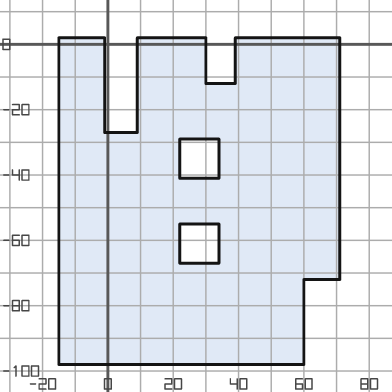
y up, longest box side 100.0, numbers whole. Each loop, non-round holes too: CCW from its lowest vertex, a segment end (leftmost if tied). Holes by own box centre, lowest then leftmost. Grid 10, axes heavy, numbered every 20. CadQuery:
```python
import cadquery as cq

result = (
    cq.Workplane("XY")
    .moveTo(-15.0, -98.0)
    .lineTo(60.0, -98.0)
    .lineTo(60.0, -72.0)
    .lineTo(71.0, -72.0)
    .lineTo(71.0, 2.0)
    .lineTo(39.0, 2.0)
    .lineTo(39.0, -12.0)
    .lineTo(30.0, -12.0)
    .lineTo(30.0, 2.0)
    .lineTo(9.0, 2.0)
    .lineTo(9.0, -27.0)
    .lineTo(-1.0, -27.0)
    .lineTo(-1.0, 2.0)
    .lineTo(-15.0, 2.0)
    .close()
    .moveTo(22.0, -67.0)
    .lineTo(34.0, -67.0)
    .lineTo(34.0, -55.0)
    .lineTo(22.0, -55.0)
    .close()
    .moveTo(22.0, -41.0)
    .lineTo(34.0, -41.0)
    .lineTo(34.0, -29.0)
    .lineTo(22.0, -29.0)
    .close()
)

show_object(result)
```